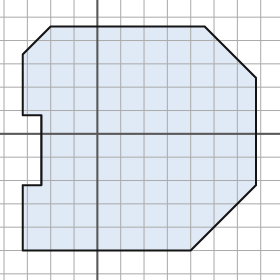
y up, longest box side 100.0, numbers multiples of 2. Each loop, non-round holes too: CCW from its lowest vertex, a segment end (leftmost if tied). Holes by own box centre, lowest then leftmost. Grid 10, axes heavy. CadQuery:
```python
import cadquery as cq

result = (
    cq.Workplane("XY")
    .moveTo(-32.0, -50.0)
    .lineTo(40.0, -50.0)
    .lineTo(68.0, -22.0)
    .lineTo(68.0, 24.0)
    .lineTo(46.0, 46.0)
    .lineTo(-20.0, 46.0)
    .lineTo(-32.0, 34.0)
    .lineTo(-32.0, 8.0)
    .lineTo(-24.0, 8.0)
    .lineTo(-24.0, -22.0)
    .lineTo(-32.0, -22.0)
    .close()
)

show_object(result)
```